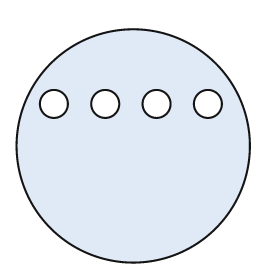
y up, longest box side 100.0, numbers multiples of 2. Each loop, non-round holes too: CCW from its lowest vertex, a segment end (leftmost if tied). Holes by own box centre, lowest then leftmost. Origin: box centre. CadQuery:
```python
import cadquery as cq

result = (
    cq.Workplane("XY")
    .moveTo(0.0, 0.0)
    .circle(50.0)
    .moveTo(-34.0, 18.0)
    .circle(6.0)
    .moveTo(-12.0, 18.0)
    .circle(6.0)
    .moveTo(10.0, 18.0)
    .circle(6.0)
    .moveTo(32.0, 18.0)
    .circle(6.0)
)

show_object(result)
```